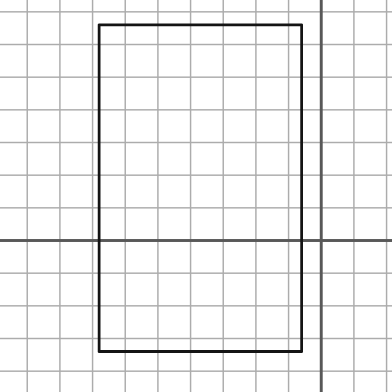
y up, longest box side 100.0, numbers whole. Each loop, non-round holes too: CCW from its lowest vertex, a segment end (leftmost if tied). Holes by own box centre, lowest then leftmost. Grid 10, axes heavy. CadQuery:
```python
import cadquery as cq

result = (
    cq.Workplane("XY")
    .moveTo(-68.0, -34.0)
    .lineTo(-6.0, -34.0)
    .lineTo(-6.0, 66.0)
    .lineTo(-68.0, 66.0)
    .close()
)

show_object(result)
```